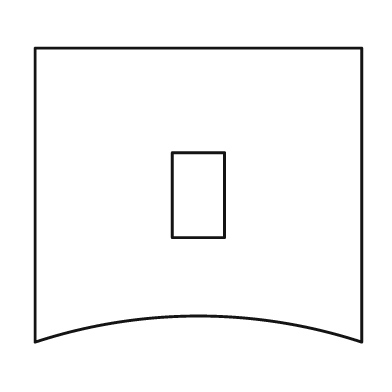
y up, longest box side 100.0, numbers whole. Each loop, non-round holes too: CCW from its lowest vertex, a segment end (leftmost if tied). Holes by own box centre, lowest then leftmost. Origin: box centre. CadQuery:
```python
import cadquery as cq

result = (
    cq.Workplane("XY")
    .moveTo(-50.0, -45.0)
    .threePointArc((0.0, -37.0), (50.0, -45.0))
    .lineTo(50.0, 45.0)
    .lineTo(-50.0, 45.0)
    .close()
    .moveTo(-8.0, -13.0)
    .lineTo(8.0, -13.0)
    .lineTo(8.0, 13.0)
    .lineTo(-8.0, 13.0)
    .close()
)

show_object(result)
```